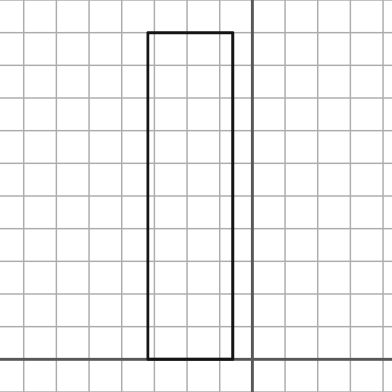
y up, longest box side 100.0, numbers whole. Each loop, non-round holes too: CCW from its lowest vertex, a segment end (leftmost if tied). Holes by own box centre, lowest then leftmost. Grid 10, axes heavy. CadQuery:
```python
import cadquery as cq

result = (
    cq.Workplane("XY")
    .moveTo(-32.0, 0.0)
    .lineTo(-6.0, 0.0)
    .lineTo(-6.0, 100.0)
    .lineTo(-32.0, 100.0)
    .close()
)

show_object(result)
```